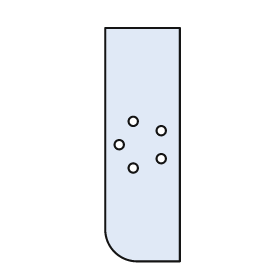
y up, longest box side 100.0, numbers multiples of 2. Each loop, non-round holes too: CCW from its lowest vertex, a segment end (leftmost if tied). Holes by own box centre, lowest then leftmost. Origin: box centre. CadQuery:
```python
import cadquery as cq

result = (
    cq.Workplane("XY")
    .moveTo(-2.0, -50.0)
    .lineTo(16.0, -50.0)
    .lineTo(16.0, 50.0)
    .lineTo(-16.0, 50.0)
    .lineTo(-16.0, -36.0)
    .threePointArc((-12.0, -46.0), (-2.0, -50.0))
    .close()
    .moveTo(-4.0, -10.0)
    .circle(2.0)
    .moveTo(8.0, -6.0)
    .circle(2.0)
    .moveTo(-10.0, 0.0)
    .circle(2.0)
    .moveTo(8.0, 6.0)
    .circle(2.0)
    .moveTo(-4.0, 10.0)
    .circle(2.0)
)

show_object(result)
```